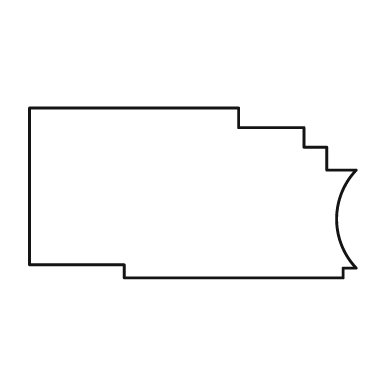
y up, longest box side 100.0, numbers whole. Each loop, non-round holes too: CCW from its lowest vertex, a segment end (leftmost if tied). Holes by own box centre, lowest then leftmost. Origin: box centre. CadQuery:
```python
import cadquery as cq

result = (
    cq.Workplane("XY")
    .moveTo(-21.0, -26.0)
    .lineTo(46.0, -26.0)
    .lineTo(46.0, -23.0)
    .lineTo(50.0, -23.0)
    .threePointArc((44.0, -8.0), (50.0, 7.0))
    .lineTo(41.0, 7.0)
    .lineTo(41.0, 14.0)
    .lineTo(34.0, 14.0)
    .lineTo(34.0, 20.0)
    .lineTo(14.0, 20.0)
    .lineTo(14.0, 26.0)
    .lineTo(-50.0, 26.0)
    .lineTo(-50.0, -22.0)
    .lineTo(-21.0, -22.0)
    .close()
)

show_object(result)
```